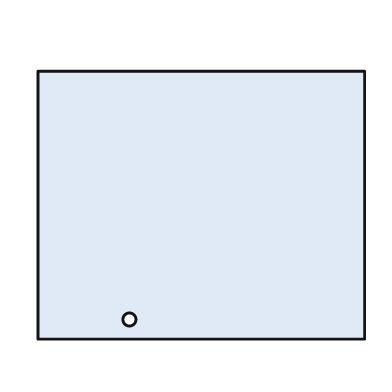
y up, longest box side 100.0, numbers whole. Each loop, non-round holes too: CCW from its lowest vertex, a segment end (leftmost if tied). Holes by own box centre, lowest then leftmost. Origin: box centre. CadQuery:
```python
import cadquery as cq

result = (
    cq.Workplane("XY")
    .moveTo(-50.0, -41.0)
    .lineTo(50.0, -41.0)
    .lineTo(50.0, 41.0)
    .lineTo(-50.0, 41.0)
    .close()
    .moveTo(-22.0, -35.0)
    .circle(2.0)
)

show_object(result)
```